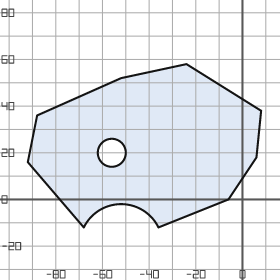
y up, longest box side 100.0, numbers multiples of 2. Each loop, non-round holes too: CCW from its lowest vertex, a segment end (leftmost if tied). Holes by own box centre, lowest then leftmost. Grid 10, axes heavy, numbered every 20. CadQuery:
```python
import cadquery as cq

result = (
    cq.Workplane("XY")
    .moveTo(-68.0, -12.0)
    .threePointArc((-52.0, -2.0), (-36.0, -12.0))
    .lineTo(-6.0, 0.0)
    .lineTo(6.0, 18.0)
    .lineTo(8.0, 38.0)
    .lineTo(-24.0, 58.0)
    .lineTo(-52.0, 52.0)
    .lineTo(-88.0, 36.0)
    .lineTo(-92.0, 16.0)
    .close()
    .moveTo(-56.0, 20.0)
    .circle(6.0)
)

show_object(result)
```